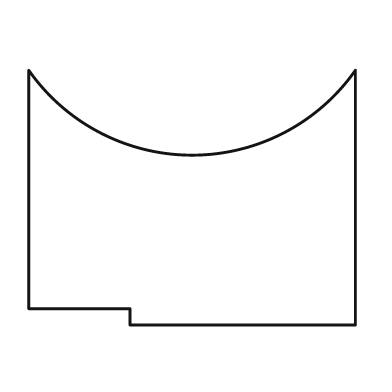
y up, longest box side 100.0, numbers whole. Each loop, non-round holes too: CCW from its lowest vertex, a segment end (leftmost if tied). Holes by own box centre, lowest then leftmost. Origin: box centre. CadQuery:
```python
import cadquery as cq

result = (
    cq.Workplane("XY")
    .moveTo(-19.0, -39.0)
    .lineTo(50.0, -39.0)
    .lineTo(50.0, 39.0)
    .threePointArc((0.0, 13.0), (-50.0, 39.0))
    .lineTo(-50.0, -34.0)
    .lineTo(-19.0, -34.0)
    .close()
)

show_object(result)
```